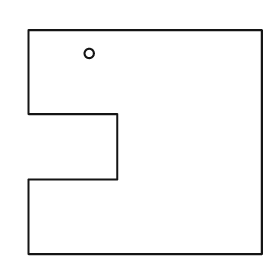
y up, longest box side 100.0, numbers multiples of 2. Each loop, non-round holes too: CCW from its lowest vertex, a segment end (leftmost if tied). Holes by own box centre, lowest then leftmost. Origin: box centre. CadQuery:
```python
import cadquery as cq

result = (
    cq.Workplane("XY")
    .moveTo(-50.0, -48.0)
    .lineTo(50.0, -48.0)
    .lineTo(50.0, 48.0)
    .lineTo(-50.0, 48.0)
    .lineTo(-50.0, 12.0)
    .lineTo(-12.0, 12.0)
    .lineTo(-12.0, -16.0)
    .lineTo(-50.0, -16.0)
    .close()
    .moveTo(-24.0, 38.0)
    .circle(2.0)
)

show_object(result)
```